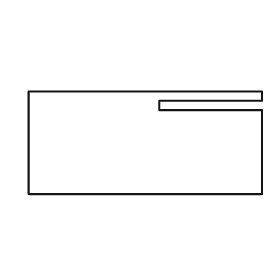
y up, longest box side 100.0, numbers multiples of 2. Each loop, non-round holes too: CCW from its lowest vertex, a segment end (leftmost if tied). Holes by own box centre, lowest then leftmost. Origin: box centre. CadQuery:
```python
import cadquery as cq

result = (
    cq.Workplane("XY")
    .moveTo(-50.0, -22.0)
    .lineTo(50.0, -22.0)
    .lineTo(50.0, 14.0)
    .lineTo(6.0, 14.0)
    .lineTo(6.0, 18.0)
    .lineTo(50.0, 18.0)
    .lineTo(50.0, 22.0)
    .lineTo(-50.0, 22.0)
    .close()
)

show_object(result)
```